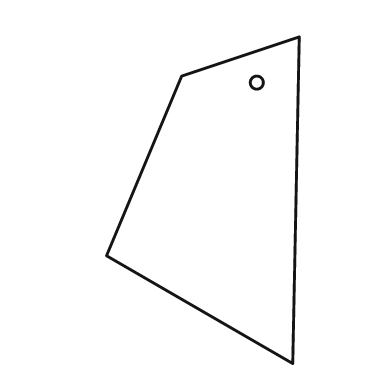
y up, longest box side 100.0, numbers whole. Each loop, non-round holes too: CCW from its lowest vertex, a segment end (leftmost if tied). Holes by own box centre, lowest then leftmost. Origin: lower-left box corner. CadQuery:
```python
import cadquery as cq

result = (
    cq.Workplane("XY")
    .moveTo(57.0, 0.0)
    .lineTo(59.0, 100.0)
    .lineTo(23.0, 88.0)
    .lineTo(0.0, 33.0)
    .close()
    .moveTo(46.0, 86.0)
    .circle(2.0)
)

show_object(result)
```